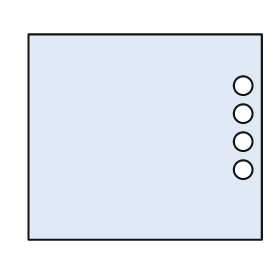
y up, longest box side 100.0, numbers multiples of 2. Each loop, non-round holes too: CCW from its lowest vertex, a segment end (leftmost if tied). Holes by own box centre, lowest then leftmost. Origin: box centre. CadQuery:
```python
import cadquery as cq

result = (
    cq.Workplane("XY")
    .moveTo(-50.0, -44.0)
    .lineTo(50.0, -44.0)
    .lineTo(50.0, 44.0)
    .lineTo(-50.0, 44.0)
    .close()
    .moveTo(42.0, -14.0)
    .circle(4.0)
    .moveTo(42.0, -2.0)
    .circle(4.0)
    .moveTo(42.0, 10.0)
    .circle(4.0)
    .moveTo(42.0, 22.0)
    .circle(4.0)
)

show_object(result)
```